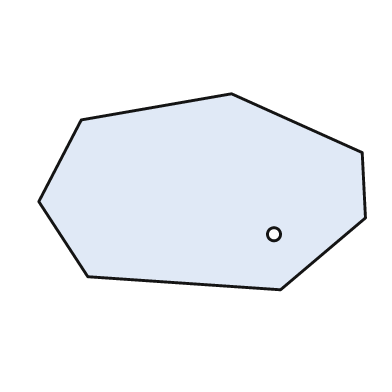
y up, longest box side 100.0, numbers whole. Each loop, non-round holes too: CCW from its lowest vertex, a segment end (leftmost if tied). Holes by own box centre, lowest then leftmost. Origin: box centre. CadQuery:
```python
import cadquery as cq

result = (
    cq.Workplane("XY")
    .moveTo(24.0, -30.0)
    .lineTo(50.0, -8.0)
    .lineTo(49.0, 12.0)
    .lineTo(9.0, 30.0)
    .lineTo(-37.0, 22.0)
    .lineTo(-50.0, -3.0)
    .lineTo(-35.0, -26.0)
    .close()
    .moveTo(22.0, -13.0)
    .circle(2.0)
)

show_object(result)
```